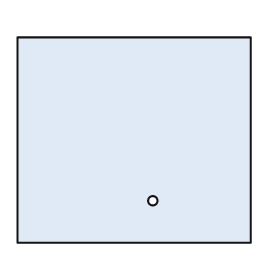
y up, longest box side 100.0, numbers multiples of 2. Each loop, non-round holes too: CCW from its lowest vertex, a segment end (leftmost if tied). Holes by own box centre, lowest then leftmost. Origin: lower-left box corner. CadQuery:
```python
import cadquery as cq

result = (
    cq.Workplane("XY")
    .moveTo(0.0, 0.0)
    .lineTo(100.0, 0.0)
    .lineTo(100.0, 88.0)
    .lineTo(0.0, 88.0)
    .close()
    .moveTo(58.0, 18.0)
    .circle(2.0)
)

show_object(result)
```